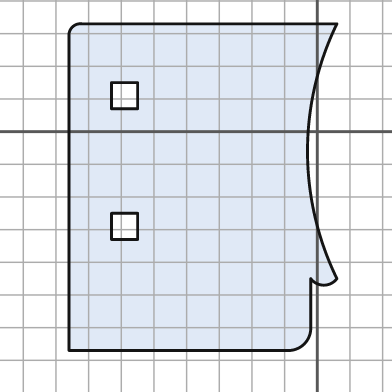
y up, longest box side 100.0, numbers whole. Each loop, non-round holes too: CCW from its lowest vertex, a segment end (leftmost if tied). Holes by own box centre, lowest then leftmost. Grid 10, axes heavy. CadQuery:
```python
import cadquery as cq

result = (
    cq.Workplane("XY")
    .moveTo(-76.0, -67.0)
    .lineTo(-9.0, -67.0)
    .threePointArc((-4.0, -65.0), (-2.0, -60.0))
    .lineTo(-2.0, -45.0)
    .threePointArc((2.0, -47.0), (6.0, -45.0))
    .threePointArc((-3.0, -6.0), (6.0, 33.0))
    .lineTo(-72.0, 33.0)
    .threePointArc((-75.0, 32.0), (-76.0, 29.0))
    .close()
    .moveTo(-63.0, -33.0)
    .lineTo(-55.0, -33.0)
    .lineTo(-55.0, -25.0)
    .lineTo(-63.0, -25.0)
    .close()
    .moveTo(-63.0, 7.0)
    .lineTo(-55.0, 7.0)
    .lineTo(-55.0, 15.0)
    .lineTo(-63.0, 15.0)
    .close()
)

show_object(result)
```